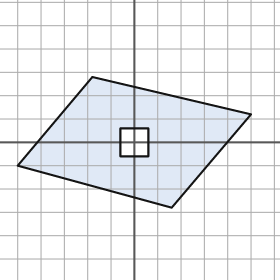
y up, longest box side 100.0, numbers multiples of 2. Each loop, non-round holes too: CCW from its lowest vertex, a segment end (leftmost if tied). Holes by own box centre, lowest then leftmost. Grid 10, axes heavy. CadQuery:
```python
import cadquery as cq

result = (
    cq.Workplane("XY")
    .moveTo(16.0, -28.0)
    .lineTo(50.0, 12.0)
    .lineTo(-18.0, 28.0)
    .lineTo(-50.0, -10.0)
    .close()
    .moveTo(-6.0, -6.0)
    .lineTo(6.0, -6.0)
    .lineTo(6.0, 6.0)
    .lineTo(-6.0, 6.0)
    .close()
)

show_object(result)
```